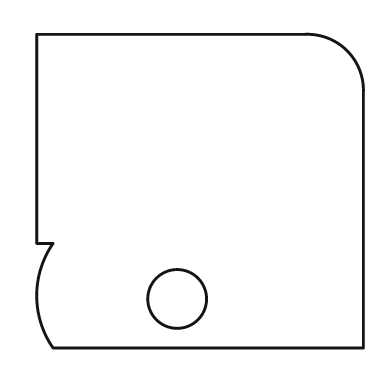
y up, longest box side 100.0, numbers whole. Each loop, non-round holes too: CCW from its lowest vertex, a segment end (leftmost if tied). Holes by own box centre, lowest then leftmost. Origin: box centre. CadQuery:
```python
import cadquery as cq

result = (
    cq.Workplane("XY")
    .moveTo(-45.0, -48.0)
    .lineTo(50.0, -48.0)
    .lineTo(50.0, 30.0)
    .threePointArc((45.0, 43.0), (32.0, 48.0))
    .lineTo(-50.0, 48.0)
    .lineTo(-50.0, -16.0)
    .lineTo(-45.0, -16.0)
    .threePointArc((-50.0, -32.0), (-45.0, -48.0))
    .close()
    .moveTo(-7.0, -33.0)
    .circle(9.0)
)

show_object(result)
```